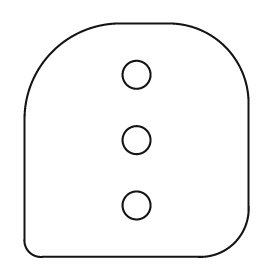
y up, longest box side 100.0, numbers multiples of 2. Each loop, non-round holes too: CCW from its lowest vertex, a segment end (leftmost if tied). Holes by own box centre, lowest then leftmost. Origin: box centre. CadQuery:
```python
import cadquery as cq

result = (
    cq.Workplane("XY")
    .moveTo(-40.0, -50.0)
    .lineTo(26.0, -50.0)
    .threePointArc((42.0, -44.0), (48.0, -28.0))
    .lineTo(48.0, 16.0)
    .threePointArc((38.0, 40.0), (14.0, 50.0))
    .lineTo(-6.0, 50.0)
    .threePointArc((-36.0, 38.0), (-48.0, 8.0))
    .lineTo(-48.0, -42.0)
    .threePointArc((-46.0, -48.0), (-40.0, -50.0))
    .close()
    .moveTo(0.0, -28.0)
    .circle(6.0)
    .moveTo(0.0, 0.0)
    .circle(6.0)
    .moveTo(0.0, 28.0)
    .circle(6.0)
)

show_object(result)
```